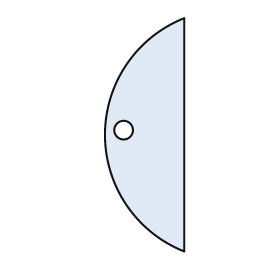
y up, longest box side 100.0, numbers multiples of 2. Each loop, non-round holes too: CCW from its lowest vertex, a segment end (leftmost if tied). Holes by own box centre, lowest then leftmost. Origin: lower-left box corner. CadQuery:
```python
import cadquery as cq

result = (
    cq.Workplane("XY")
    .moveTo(34.0, 0.0)
    .lineTo(34.0, 100.0)
    .threePointArc((0.0, 50.0), (34.0, 0.0))
    .close()
    .moveTo(8.0, 52.0)
    .circle(4.0)
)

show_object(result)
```